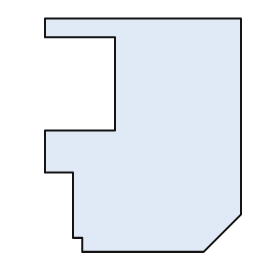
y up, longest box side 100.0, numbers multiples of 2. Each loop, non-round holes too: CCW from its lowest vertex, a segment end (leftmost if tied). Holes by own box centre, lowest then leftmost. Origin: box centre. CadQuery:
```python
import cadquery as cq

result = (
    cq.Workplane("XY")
    .moveTo(-26.0, -50.0)
    .lineTo(26.0, -50.0)
    .lineTo(42.0, -34.0)
    .lineTo(42.0, 50.0)
    .lineTo(-42.0, 50.0)
    .lineTo(-42.0, 42.0)
    .lineTo(-12.0, 42.0)
    .lineTo(-12.0, 2.0)
    .lineTo(-42.0, 2.0)
    .lineTo(-42.0, -16.0)
    .lineTo(-30.0, -16.0)
    .lineTo(-30.0, -44.0)
    .lineTo(-26.0, -44.0)
    .close()
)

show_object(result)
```